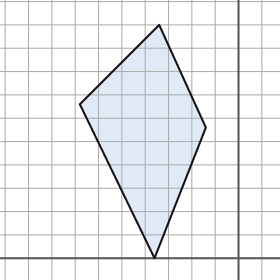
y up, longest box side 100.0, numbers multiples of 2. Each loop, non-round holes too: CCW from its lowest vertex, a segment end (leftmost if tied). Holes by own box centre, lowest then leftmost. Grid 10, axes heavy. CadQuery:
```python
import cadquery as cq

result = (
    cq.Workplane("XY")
    .moveTo(-36.0, 0.0)
    .lineTo(-14.0, 56.0)
    .lineTo(-34.0, 100.0)
    .lineTo(-68.0, 66.0)
    .close()
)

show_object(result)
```